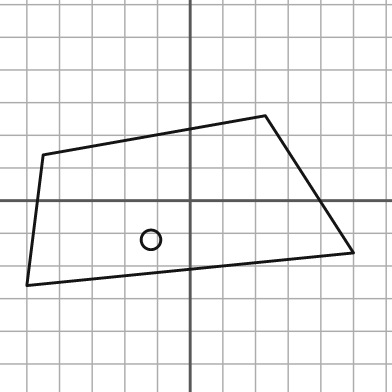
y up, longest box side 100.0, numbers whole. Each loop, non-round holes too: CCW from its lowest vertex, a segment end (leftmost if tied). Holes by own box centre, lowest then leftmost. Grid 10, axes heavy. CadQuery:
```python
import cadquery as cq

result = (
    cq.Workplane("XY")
    .moveTo(-50.0, -26.0)
    .lineTo(50.0, -16.0)
    .lineTo(23.0, 26.0)
    .lineTo(-45.0, 14.0)
    .close()
    .moveTo(-12.0, -12.0)
    .circle(3.0)
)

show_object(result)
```